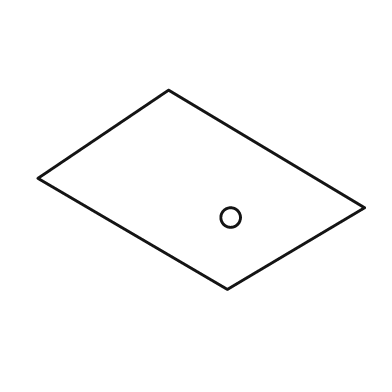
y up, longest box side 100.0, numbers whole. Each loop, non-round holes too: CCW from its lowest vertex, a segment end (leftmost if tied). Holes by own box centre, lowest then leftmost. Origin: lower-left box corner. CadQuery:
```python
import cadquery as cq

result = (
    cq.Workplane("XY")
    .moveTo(58.0, 0.0)
    .lineTo(100.0, 25.0)
    .lineTo(40.0, 61.0)
    .lineTo(0.0, 34.0)
    .close()
    .moveTo(59.0, 22.0)
    .circle(3.0)
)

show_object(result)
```